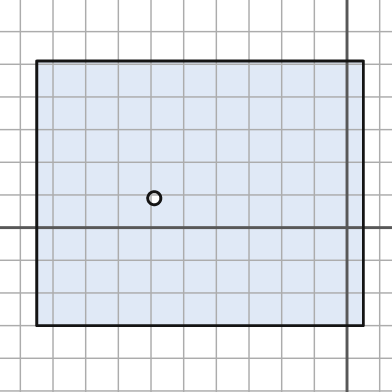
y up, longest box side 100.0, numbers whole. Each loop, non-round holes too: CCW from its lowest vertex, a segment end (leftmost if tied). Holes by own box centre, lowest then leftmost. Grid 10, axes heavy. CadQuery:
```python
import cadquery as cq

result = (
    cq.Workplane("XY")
    .moveTo(-95.0, -30.0)
    .lineTo(5.0, -30.0)
    .lineTo(5.0, 51.0)
    .lineTo(-95.0, 51.0)
    .close()
    .moveTo(-59.0, 9.0)
    .circle(2.0)
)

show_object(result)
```